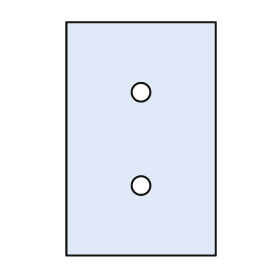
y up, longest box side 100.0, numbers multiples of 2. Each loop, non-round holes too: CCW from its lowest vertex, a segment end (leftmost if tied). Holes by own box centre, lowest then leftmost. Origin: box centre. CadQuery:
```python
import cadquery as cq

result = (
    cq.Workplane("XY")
    .moveTo(-32.0, -50.0)
    .lineTo(32.0, -50.0)
    .lineTo(32.0, 50.0)
    .lineTo(-32.0, 50.0)
    .close()
    .moveTo(0.0, -20.0)
    .circle(4.0)
    .moveTo(0.0, 20.0)
    .circle(4.0)
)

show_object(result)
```